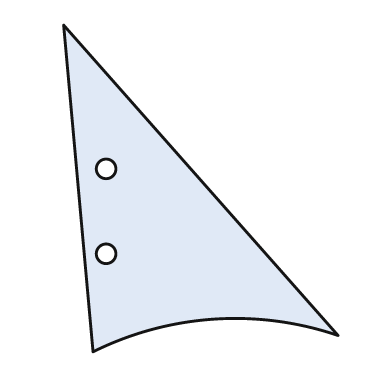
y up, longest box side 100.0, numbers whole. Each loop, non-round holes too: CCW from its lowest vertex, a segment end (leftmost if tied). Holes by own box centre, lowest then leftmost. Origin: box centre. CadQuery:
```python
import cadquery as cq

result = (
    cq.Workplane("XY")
    .moveTo(-33.0, -50.0)
    .threePointArc((4.0, -40.0), (42.0, -45.0))
    .lineTo(-42.0, 50.0)
    .close()
    .moveTo(-29.0, -20.0)
    .circle(3.0)
    .moveTo(-29.0, 6.0)
    .circle(3.0)
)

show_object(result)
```